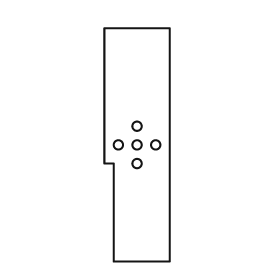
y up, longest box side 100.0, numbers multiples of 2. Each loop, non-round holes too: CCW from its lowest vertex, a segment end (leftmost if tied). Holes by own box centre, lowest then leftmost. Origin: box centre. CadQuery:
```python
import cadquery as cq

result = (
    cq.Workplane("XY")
    .moveTo(-10.0, -50.0)
    .lineTo(14.0, -50.0)
    .lineTo(14.0, 50.0)
    .lineTo(-14.0, 50.0)
    .lineTo(-14.0, -8.0)
    .lineTo(-10.0, -8.0)
    .close()
    .moveTo(0.0, -8.0)
    .circle(2.0)
    .moveTo(-8.0, 0.0)
    .circle(2.0)
    .moveTo(0.0, 0.0)
    .circle(2.0)
    .moveTo(8.0, 0.0)
    .circle(2.0)
    .moveTo(0.0, 8.0)
    .circle(2.0)
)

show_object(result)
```